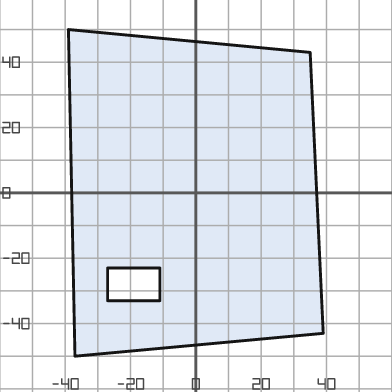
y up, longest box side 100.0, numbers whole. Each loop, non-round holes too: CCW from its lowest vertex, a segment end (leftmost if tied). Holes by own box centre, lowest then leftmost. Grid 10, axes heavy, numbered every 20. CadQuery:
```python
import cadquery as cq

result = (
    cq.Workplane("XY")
    .moveTo(-37.0, -50.0)
    .lineTo(39.0, -43.0)
    .lineTo(35.0, 43.0)
    .lineTo(-39.0, 50.0)
    .close()
    .moveTo(-27.0, -33.0)
    .lineTo(-11.0, -33.0)
    .lineTo(-11.0, -23.0)
    .lineTo(-27.0, -23.0)
    .close()
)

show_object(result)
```